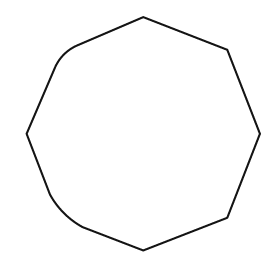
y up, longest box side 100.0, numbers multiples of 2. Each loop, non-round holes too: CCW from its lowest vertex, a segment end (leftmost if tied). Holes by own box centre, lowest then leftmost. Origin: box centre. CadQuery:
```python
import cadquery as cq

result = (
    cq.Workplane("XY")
    .moveTo(0.0, -50.0)
    .lineTo(36.0, -36.0)
    .lineTo(50.0, 0.0)
    .lineTo(36.0, 36.0)
    .lineTo(0.0, 50.0)
    .lineTo(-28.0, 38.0)
    .threePointArc((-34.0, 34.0), (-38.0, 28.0))
    .lineTo(-50.0, 0.0)
    .lineTo(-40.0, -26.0)
    .threePointArc((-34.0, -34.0), (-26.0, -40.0))
    .close()
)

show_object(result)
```